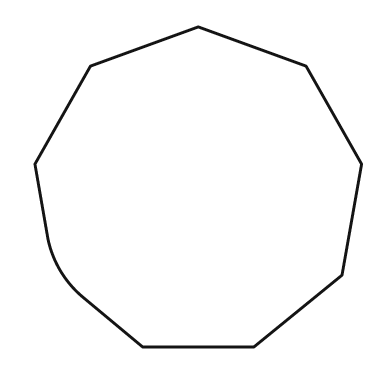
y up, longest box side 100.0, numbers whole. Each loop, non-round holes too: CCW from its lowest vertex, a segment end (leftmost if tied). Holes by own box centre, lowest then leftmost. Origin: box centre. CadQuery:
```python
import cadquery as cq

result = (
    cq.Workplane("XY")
    .moveTo(-17.0, -49.0)
    .lineTo(17.0, -49.0)
    .lineTo(44.0, -27.0)
    .lineTo(50.0, 7.0)
    .lineTo(33.0, 37.0)
    .lineTo(0.0, 49.0)
    .lineTo(-33.0, 37.0)
    .lineTo(-50.0, 7.0)
    .lineTo(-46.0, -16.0)
    .threePointArc((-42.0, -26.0), (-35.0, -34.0))
    .close()
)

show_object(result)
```